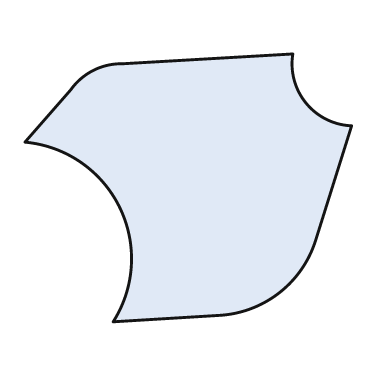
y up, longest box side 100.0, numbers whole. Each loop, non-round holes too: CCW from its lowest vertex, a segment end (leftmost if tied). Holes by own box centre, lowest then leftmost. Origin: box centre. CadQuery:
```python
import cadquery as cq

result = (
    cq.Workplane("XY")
    .moveTo(-23.0, -41.0)
    .lineTo(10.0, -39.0)
    .threePointArc((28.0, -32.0), (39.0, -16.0))
    .lineTo(50.0, 19.0)
    .threePointArc((36.0, 26.0), (32.0, 41.0))
    .lineTo(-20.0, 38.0)
    .threePointArc((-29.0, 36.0), (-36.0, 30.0))
    .lineTo(-50.0, 14.0)
    .threePointArc((-21.0, -6.0), (-23.0, -41.0))
    .close()
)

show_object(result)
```